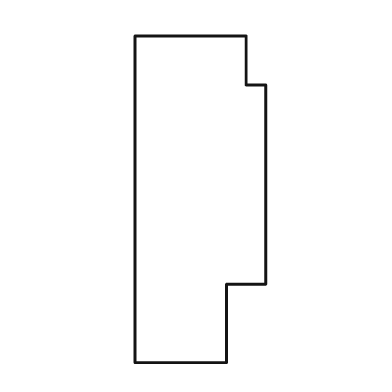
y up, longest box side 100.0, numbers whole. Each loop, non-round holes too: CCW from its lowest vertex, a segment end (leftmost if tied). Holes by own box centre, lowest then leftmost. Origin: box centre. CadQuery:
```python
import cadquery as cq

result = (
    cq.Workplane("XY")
    .moveTo(-20.0, -50.0)
    .lineTo(8.0, -50.0)
    .lineTo(8.0, -26.0)
    .lineTo(20.0, -26.0)
    .lineTo(20.0, 35.0)
    .lineTo(14.0, 35.0)
    .lineTo(14.0, 50.0)
    .lineTo(-20.0, 50.0)
    .close()
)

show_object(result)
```